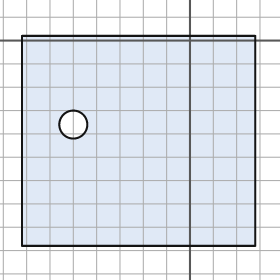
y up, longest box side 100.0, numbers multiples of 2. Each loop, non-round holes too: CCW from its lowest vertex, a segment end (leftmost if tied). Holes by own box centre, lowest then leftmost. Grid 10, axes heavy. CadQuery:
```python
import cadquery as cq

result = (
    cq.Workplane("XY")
    .moveTo(-72.0, -88.0)
    .lineTo(28.0, -88.0)
    .lineTo(28.0, 2.0)
    .lineTo(-72.0, 2.0)
    .close()
    .moveTo(-50.0, -36.0)
    .circle(6.0)
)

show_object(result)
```